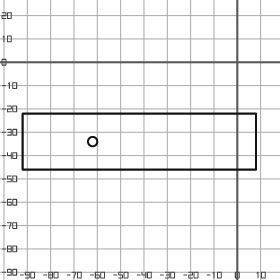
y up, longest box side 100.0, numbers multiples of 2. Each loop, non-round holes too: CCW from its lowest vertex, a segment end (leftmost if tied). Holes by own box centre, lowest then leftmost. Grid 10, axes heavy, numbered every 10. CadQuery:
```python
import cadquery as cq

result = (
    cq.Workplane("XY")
    .moveTo(-92.0, -46.0)
    .lineTo(8.0, -46.0)
    .lineTo(8.0, -22.0)
    .lineTo(-92.0, -22.0)
    .close()
    .moveTo(-62.0, -34.0)
    .circle(2.0)
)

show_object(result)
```